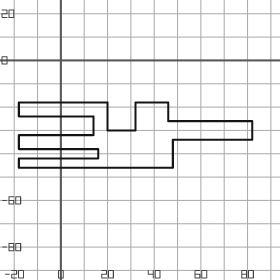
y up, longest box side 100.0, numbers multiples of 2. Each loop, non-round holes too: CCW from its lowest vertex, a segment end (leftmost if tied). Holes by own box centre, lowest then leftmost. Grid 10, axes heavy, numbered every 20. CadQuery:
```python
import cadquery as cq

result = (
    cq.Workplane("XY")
    .moveTo(-18.0, -46.0)
    .lineTo(48.0, -46.0)
    .lineTo(48.0, -34.0)
    .lineTo(82.0, -34.0)
    .lineTo(82.0, -26.0)
    .lineTo(46.0, -26.0)
    .lineTo(46.0, -18.0)
    .lineTo(32.0, -18.0)
    .lineTo(32.0, -30.0)
    .lineTo(20.0, -30.0)
    .lineTo(20.0, -18.0)
    .lineTo(-18.0, -18.0)
    .lineTo(-18.0, -24.0)
    .lineTo(14.0, -24.0)
    .lineTo(14.0, -32.0)
    .lineTo(-18.0, -32.0)
    .lineTo(-18.0, -38.0)
    .lineTo(16.0, -38.0)
    .lineTo(16.0, -42.0)
    .lineTo(-18.0, -42.0)
    .close()
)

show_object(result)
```